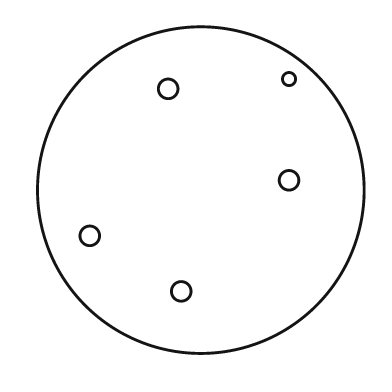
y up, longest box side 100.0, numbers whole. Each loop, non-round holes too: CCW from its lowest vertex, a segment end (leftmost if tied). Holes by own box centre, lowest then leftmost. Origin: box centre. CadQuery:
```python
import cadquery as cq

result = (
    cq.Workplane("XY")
    .moveTo(0.0, 0.0)
    .circle(50.0)
    .moveTo(-6.0, -31.0)
    .circle(3.0)
    .moveTo(-34.0, -14.0)
    .circle(3.0)
    .moveTo(27.0, 3.0)
    .circle(3.0)
    .moveTo(-10.0, 31.0)
    .circle(3.0)
    .moveTo(27.0, 34.0)
    .circle(2.0)
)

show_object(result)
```